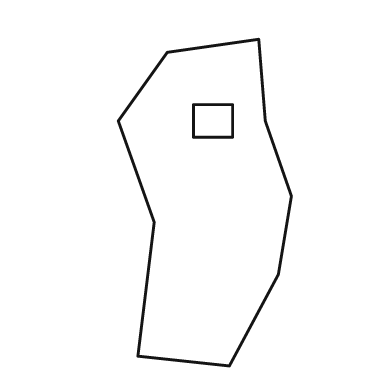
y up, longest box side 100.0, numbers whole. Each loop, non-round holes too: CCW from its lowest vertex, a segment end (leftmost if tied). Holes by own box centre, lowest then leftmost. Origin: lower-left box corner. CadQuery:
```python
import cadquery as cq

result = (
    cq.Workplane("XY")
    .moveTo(34.0, 0.0)
    .lineTo(49.0, 28.0)
    .lineTo(53.0, 52.0)
    .lineTo(45.0, 75.0)
    .lineTo(43.0, 100.0)
    .lineTo(15.0, 96.0)
    .lineTo(0.0, 75.0)
    .lineTo(11.0, 44.0)
    .lineTo(6.0, 3.0)
    .close()
    .moveTo(23.0, 70.0)
    .lineTo(35.0, 70.0)
    .lineTo(35.0, 80.0)
    .lineTo(23.0, 80.0)
    .close()
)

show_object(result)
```